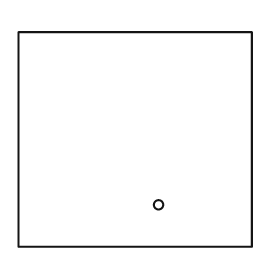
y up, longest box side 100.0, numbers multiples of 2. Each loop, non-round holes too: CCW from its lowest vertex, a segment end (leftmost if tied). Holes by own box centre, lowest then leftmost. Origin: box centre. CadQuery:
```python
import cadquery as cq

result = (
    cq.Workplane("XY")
    .moveTo(-50.0, -46.0)
    .lineTo(50.0, -46.0)
    .lineTo(50.0, 46.0)
    .lineTo(-50.0, 46.0)
    .close()
    .moveTo(10.0, -28.0)
    .circle(2.0)
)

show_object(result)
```